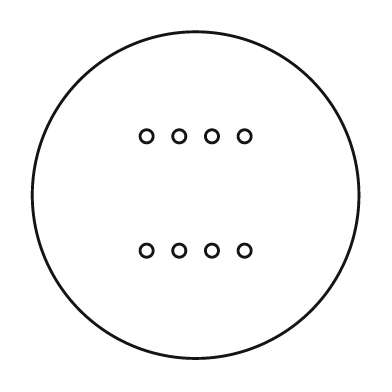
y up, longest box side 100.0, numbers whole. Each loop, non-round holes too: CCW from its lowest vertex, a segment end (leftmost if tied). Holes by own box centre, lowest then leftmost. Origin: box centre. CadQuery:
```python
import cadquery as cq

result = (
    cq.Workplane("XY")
    .moveTo(0.0, 0.0)
    .circle(50.0)
    .moveTo(-15.0, -17.0)
    .circle(2.0)
    .moveTo(-5.0, -17.0)
    .circle(2.0)
    .moveTo(5.0, -17.0)
    .circle(2.0)
    .moveTo(15.0, -17.0)
    .circle(2.0)
    .moveTo(-15.0, 18.0)
    .circle(2.0)
    .moveTo(-5.0, 18.0)
    .circle(2.0)
    .moveTo(5.0, 18.0)
    .circle(2.0)
    .moveTo(15.0, 18.0)
    .circle(2.0)
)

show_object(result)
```